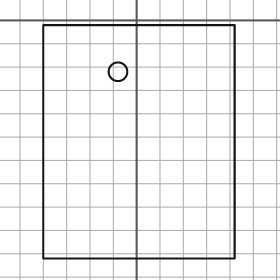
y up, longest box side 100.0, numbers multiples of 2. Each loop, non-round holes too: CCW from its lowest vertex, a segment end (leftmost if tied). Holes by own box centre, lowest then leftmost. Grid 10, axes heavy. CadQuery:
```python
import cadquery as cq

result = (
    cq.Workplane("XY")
    .moveTo(-40.0, -102.0)
    .lineTo(42.0, -102.0)
    .lineTo(42.0, -2.0)
    .lineTo(-40.0, -2.0)
    .close()
    .moveTo(-8.0, -22.0)
    .circle(4.0)
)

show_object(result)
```